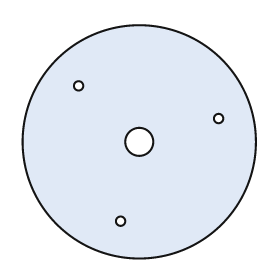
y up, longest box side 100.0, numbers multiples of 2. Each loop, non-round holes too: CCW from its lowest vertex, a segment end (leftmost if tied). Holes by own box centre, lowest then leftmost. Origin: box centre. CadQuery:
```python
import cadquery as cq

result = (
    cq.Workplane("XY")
    .moveTo(0.0, 0.0)
    .circle(50.0)
    .moveTo(-8.0, -34.0)
    .circle(2.0)
    .moveTo(0.0, 0.0)
    .circle(6.0)
    .moveTo(34.0, 10.0)
    .circle(2.0)
    .moveTo(-26.0, 24.0)
    .circle(2.0)
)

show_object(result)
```